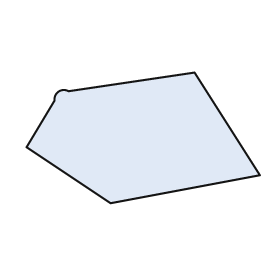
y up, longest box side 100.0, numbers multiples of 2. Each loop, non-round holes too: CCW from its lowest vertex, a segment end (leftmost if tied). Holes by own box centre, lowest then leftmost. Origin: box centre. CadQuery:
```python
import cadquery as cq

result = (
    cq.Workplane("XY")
    .moveTo(-14.0, -28.0)
    .lineTo(50.0, -16.0)
    .lineTo(22.0, 28.0)
    .lineTo(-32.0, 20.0)
    .threePointArc((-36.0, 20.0), (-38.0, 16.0))
    .lineTo(-50.0, -4.0)
    .close()
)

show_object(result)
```